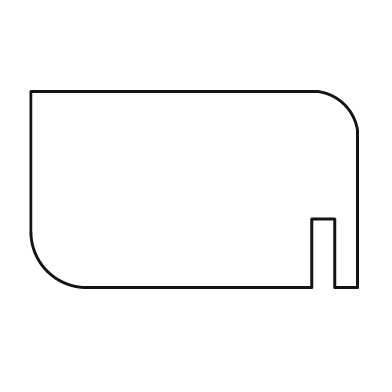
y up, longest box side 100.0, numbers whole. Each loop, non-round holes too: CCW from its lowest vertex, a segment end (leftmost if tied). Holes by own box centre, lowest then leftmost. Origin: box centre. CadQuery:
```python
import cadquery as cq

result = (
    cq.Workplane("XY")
    .moveTo(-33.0, -30.0)
    .lineTo(36.0, -30.0)
    .lineTo(36.0, -9.0)
    .lineTo(43.0, -9.0)
    .lineTo(43.0, -30.0)
    .lineTo(50.0, -30.0)
    .lineTo(50.0, 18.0)
    .threePointArc((46.0, 26.0), (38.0, 30.0))
    .lineTo(-50.0, 30.0)
    .lineTo(-50.0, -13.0)
    .threePointArc((-45.0, -25.0), (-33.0, -30.0))
    .close()
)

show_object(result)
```